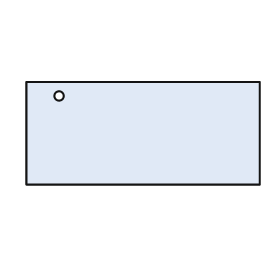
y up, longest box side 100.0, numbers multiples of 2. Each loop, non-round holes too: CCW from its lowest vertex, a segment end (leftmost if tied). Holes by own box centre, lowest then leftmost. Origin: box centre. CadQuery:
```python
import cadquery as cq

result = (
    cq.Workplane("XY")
    .moveTo(-50.0, -22.0)
    .lineTo(50.0, -22.0)
    .lineTo(50.0, 22.0)
    .lineTo(-50.0, 22.0)
    .close()
    .moveTo(-36.0, 16.0)
    .circle(2.0)
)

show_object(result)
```